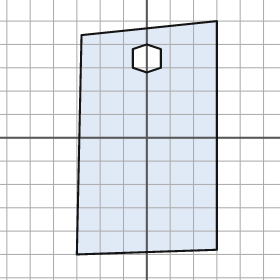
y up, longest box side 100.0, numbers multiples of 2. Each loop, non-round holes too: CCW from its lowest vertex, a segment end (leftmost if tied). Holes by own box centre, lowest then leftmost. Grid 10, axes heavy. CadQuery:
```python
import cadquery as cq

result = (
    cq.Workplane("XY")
    .moveTo(-30.0, -50.0)
    .lineTo(30.0, -48.0)
    .lineTo(30.0, 50.0)
    .lineTo(-28.0, 44.0)
    .close()
    .moveTo(0.0, 28.0)
    .lineTo(6.0, 30.0)
    .lineTo(6.0, 38.0)
    .lineTo(0.0, 40.0)
    .lineTo(-6.0, 38.0)
    .lineTo(-6.0, 30.0)
    .close()
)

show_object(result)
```